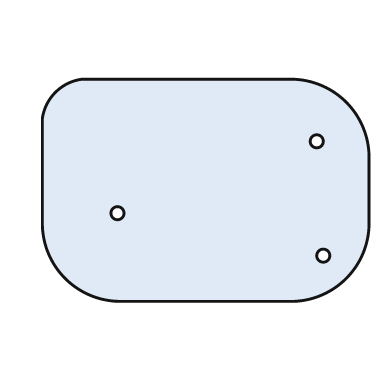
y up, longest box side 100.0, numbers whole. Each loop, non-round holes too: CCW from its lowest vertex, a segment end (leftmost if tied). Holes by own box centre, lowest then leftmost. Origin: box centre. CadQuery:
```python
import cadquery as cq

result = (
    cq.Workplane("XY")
    .moveTo(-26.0, -34.0)
    .lineTo(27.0, -34.0)
    .threePointArc((43.0, -27.0), (50.0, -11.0))
    .lineTo(50.0, 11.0)
    .threePointArc((43.0, 27.0), (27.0, 34.0))
    .lineTo(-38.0, 34.0)
    .threePointArc((-46.0, 30.0), (-50.0, 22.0))
    .lineTo(-50.0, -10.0)
    .threePointArc((-43.0, -27.0), (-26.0, -34.0))
    .close()
    .moveTo(36.0, -20.0)
    .circle(2.0)
    .moveTo(-27.0, -7.0)
    .circle(2.0)
    .moveTo(34.0, 15.0)
    .circle(2.0)
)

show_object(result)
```